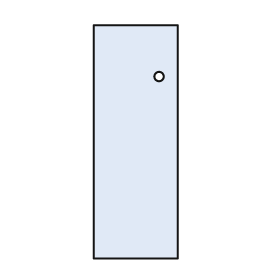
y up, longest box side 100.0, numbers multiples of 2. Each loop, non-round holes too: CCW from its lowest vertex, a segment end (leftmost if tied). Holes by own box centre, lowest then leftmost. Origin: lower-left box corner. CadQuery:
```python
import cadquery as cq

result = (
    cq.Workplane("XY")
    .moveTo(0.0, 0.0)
    .lineTo(36.0, 0.0)
    .lineTo(36.0, 100.0)
    .lineTo(0.0, 100.0)
    .close()
    .moveTo(28.0, 78.0)
    .circle(2.0)
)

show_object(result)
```